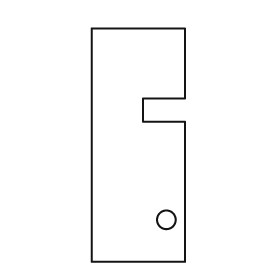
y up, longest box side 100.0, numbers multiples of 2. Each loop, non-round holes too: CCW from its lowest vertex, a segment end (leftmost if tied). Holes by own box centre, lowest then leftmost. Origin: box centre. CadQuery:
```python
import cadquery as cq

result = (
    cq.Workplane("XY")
    .moveTo(-20.0, -50.0)
    .lineTo(20.0, -50.0)
    .lineTo(20.0, 10.0)
    .lineTo(2.0, 10.0)
    .lineTo(2.0, 20.0)
    .lineTo(20.0, 20.0)
    .lineTo(20.0, 50.0)
    .lineTo(-20.0, 50.0)
    .close()
    .moveTo(12.0, -32.0)
    .circle(4.0)
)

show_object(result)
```